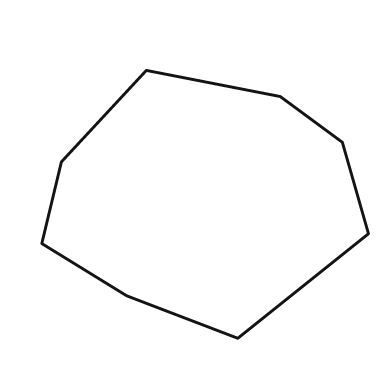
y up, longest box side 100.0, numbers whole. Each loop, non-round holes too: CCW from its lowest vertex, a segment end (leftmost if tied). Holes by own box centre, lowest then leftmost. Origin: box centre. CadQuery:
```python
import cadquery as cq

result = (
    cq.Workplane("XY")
    .moveTo(10.0, -41.0)
    .lineTo(50.0, -9.0)
    .lineTo(42.0, 19.0)
    .lineTo(23.0, 33.0)
    .lineTo(-18.0, 41.0)
    .lineTo(-44.0, 13.0)
    .lineTo(-50.0, -12.0)
    .lineTo(-24.0, -28.0)
    .close()
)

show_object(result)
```